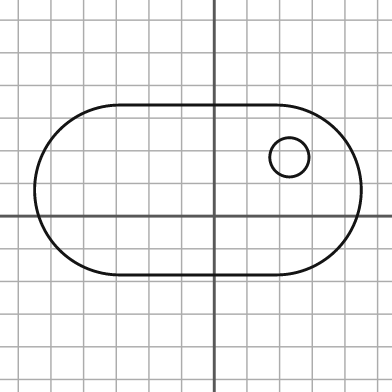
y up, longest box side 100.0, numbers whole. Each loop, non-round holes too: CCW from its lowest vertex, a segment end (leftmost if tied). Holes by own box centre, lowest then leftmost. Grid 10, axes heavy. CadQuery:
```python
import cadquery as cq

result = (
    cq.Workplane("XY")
    .moveTo(-29.0, -18.0)
    .lineTo(19.0, -18.0)
    .threePointArc((45.0, 8.0), (19.0, 34.0))
    .lineTo(-29.0, 34.0)
    .threePointArc((-55.0, 8.0), (-29.0, -18.0))
    .close()
    .moveTo(23.0, 18.0)
    .circle(6.0)
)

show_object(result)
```